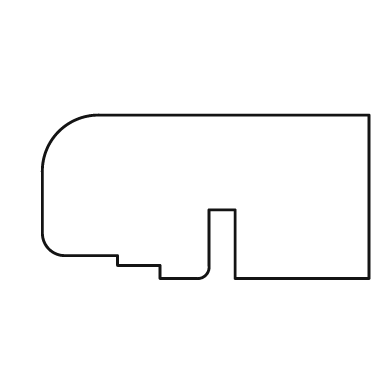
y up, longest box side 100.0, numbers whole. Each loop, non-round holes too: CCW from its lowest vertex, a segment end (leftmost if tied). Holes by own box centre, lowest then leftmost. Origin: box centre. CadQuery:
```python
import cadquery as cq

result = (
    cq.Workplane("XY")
    .moveTo(-14.0, -25.0)
    .lineTo(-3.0, -25.0)
    .threePointArc((0.0, -24.0), (1.0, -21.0))
    .lineTo(1.0, -4.0)
    .lineTo(9.0, -4.0)
    .lineTo(9.0, -25.0)
    .lineTo(50.0, -25.0)
    .lineTo(50.0, 25.0)
    .lineTo(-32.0, 25.0)
    .threePointArc((-45.0, 20.0), (-50.0, 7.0))
    .lineTo(-50.0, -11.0)
    .threePointArc((-48.0, -16.0), (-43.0, -18.0))
    .lineTo(-27.0, -18.0)
    .lineTo(-27.0, -21.0)
    .lineTo(-14.0, -21.0)
    .close()
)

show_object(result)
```